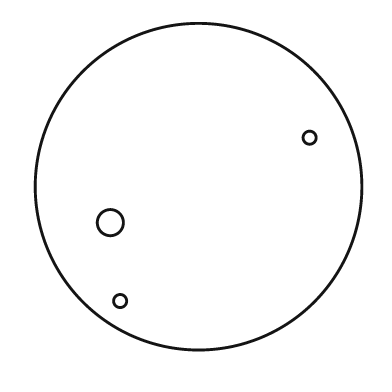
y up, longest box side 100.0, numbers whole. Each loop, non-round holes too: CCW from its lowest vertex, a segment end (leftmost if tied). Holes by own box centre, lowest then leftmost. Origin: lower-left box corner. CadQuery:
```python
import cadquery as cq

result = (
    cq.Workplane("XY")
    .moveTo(50.0, 50.0)
    .circle(50.0)
    .moveTo(26.0, 15.0)
    .circle(2.0)
    .moveTo(23.0, 39.0)
    .circle(4.0)
    .moveTo(84.0, 65.0)
    .circle(2.0)
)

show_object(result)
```